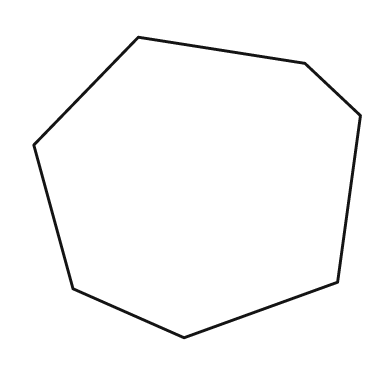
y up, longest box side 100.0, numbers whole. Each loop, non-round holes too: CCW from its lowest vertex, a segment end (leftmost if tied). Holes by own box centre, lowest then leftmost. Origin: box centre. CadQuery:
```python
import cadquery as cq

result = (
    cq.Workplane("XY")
    .moveTo(-4.0, -46.0)
    .lineTo(43.0, -29.0)
    .lineTo(50.0, 22.0)
    .lineTo(33.0, 38.0)
    .lineTo(-18.0, 46.0)
    .lineTo(-50.0, 13.0)
    .lineTo(-38.0, -31.0)
    .close()
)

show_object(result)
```